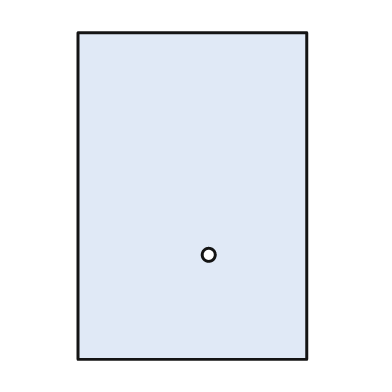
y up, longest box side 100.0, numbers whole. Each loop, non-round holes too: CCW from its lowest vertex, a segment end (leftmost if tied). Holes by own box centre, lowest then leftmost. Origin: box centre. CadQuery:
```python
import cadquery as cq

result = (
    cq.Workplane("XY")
    .moveTo(-35.0, -50.0)
    .lineTo(35.0, -50.0)
    .lineTo(35.0, 50.0)
    .lineTo(-35.0, 50.0)
    .close()
    .moveTo(5.0, -18.0)
    .circle(2.0)
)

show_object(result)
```